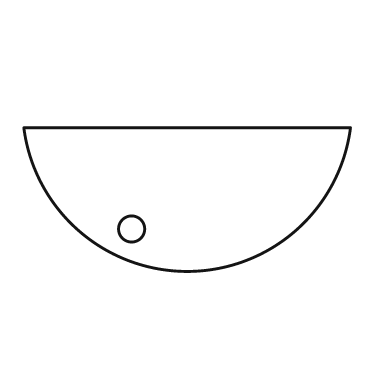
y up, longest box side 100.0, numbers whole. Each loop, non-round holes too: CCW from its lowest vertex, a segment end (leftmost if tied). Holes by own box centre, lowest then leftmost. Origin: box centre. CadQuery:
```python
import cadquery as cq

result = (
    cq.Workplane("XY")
    .moveTo(-50.0, 22.0)
    .threePointArc((0.0, -22.0), (50.0, 22.0))
    .close()
    .moveTo(-17.0, -9.0)
    .circle(4.0)
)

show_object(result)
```